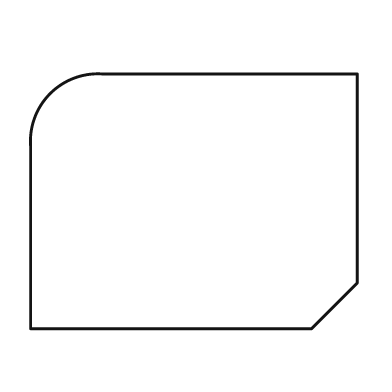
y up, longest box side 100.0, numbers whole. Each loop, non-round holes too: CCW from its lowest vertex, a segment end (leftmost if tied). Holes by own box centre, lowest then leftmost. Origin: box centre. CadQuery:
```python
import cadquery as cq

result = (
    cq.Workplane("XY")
    .moveTo(-50.0, -39.0)
    .lineTo(36.0, -39.0)
    .lineTo(50.0, -25.0)
    .lineTo(50.0, 39.0)
    .lineTo(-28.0, 39.0)
    .threePointArc((-44.0, 33.0), (-50.0, 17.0))
    .close()
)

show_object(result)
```